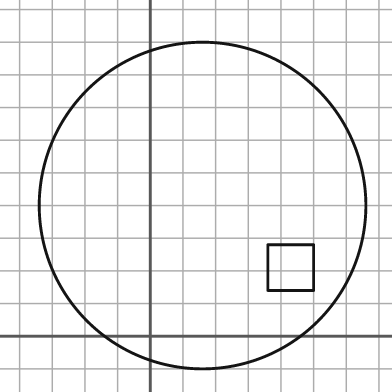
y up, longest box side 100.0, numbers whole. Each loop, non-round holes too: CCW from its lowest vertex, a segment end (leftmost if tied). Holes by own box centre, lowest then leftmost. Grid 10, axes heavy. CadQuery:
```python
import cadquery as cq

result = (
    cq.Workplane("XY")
    .moveTo(16.0, 40.0)
    .circle(50.0)
    .moveTo(36.0, 14.0)
    .lineTo(50.0, 14.0)
    .lineTo(50.0, 28.0)
    .lineTo(36.0, 28.0)
    .close()
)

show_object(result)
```